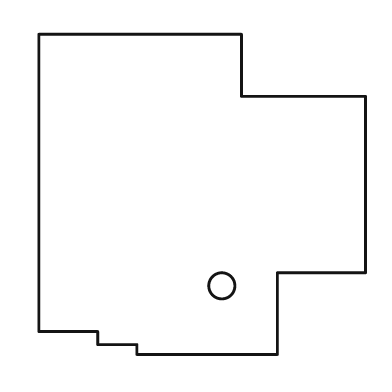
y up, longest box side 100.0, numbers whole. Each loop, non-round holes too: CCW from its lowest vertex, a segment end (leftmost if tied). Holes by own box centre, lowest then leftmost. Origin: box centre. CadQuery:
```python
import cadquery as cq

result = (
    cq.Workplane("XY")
    .moveTo(-20.0, -49.0)
    .lineTo(23.0, -49.0)
    .lineTo(23.0, -24.0)
    .lineTo(50.0, -24.0)
    .lineTo(50.0, 30.0)
    .lineTo(12.0, 30.0)
    .lineTo(12.0, 49.0)
    .lineTo(-50.0, 49.0)
    .lineTo(-50.0, -42.0)
    .lineTo(-32.0, -42.0)
    .lineTo(-32.0, -46.0)
    .lineTo(-20.0, -46.0)
    .close()
    .moveTo(6.0, -28.0)
    .circle(4.0)
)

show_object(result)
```